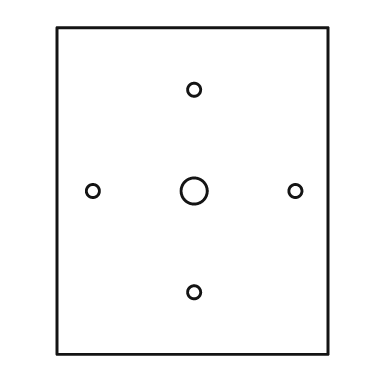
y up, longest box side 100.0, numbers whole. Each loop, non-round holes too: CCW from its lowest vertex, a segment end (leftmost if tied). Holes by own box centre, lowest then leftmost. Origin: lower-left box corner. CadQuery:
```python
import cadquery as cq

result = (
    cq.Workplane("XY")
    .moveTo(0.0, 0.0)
    .lineTo(83.0, 0.0)
    .lineTo(83.0, 100.0)
    .lineTo(0.0, 100.0)
    .close()
    .moveTo(42.0, 19.0)
    .circle(2.0)
    .moveTo(11.0, 50.0)
    .circle(2.0)
    .moveTo(42.0, 50.0)
    .circle(4.0)
    .moveTo(73.0, 50.0)
    .circle(2.0)
    .moveTo(42.0, 81.0)
    .circle(2.0)
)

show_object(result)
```